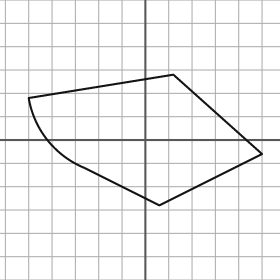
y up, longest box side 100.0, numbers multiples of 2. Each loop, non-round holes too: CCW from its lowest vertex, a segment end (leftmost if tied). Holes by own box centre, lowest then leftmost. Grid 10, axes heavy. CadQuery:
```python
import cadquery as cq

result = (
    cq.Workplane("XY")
    .moveTo(6.0, -28.0)
    .lineTo(50.0, -6.0)
    .lineTo(12.0, 28.0)
    .lineTo(-50.0, 18.0)
    .threePointArc((-42.0, 0.0), (-26.0, -12.0))
    .close()
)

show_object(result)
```